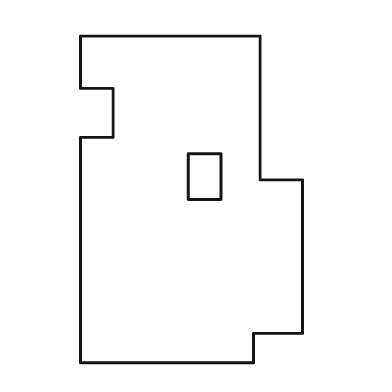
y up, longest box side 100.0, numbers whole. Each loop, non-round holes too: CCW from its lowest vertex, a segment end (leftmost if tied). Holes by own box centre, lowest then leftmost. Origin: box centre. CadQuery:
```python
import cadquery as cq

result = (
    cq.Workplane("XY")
    .moveTo(-34.0, -50.0)
    .lineTo(19.0, -50.0)
    .lineTo(19.0, -41.0)
    .lineTo(34.0, -41.0)
    .lineTo(34.0, 6.0)
    .lineTo(21.0, 6.0)
    .lineTo(21.0, 50.0)
    .lineTo(-34.0, 50.0)
    .lineTo(-34.0, 34.0)
    .lineTo(-24.0, 34.0)
    .lineTo(-24.0, 19.0)
    .lineTo(-34.0, 19.0)
    .close()
    .moveTo(-1.0, 0.0)
    .lineTo(9.0, 0.0)
    .lineTo(9.0, 14.0)
    .lineTo(-1.0, 14.0)
    .close()
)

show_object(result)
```